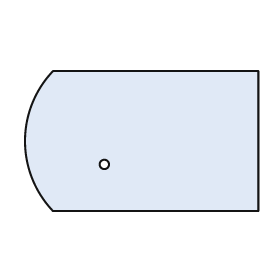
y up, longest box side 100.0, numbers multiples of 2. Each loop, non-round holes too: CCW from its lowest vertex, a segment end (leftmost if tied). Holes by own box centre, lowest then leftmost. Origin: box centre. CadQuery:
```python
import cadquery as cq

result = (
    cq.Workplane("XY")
    .moveTo(-38.0, -30.0)
    .lineTo(50.0, -30.0)
    .lineTo(50.0, 30.0)
    .lineTo(-38.0, 30.0)
    .threePointArc((-50.0, 0.0), (-38.0, -30.0))
    .close()
    .moveTo(-16.0, -10.0)
    .circle(2.0)
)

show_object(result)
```